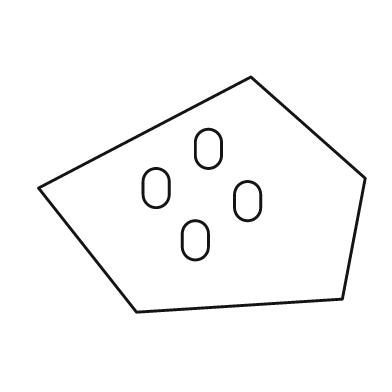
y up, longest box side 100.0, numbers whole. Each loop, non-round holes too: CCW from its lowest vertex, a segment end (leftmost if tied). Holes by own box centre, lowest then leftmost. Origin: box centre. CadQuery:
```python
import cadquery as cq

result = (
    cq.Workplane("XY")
    .moveTo(-20.0, -36.0)
    .lineTo(43.0, -32.0)
    .lineTo(50.0, 5.0)
    .lineTo(15.0, 36.0)
    .lineTo(-50.0, 2.0)
    .close()
    .moveTo(-6.0, -16.0)
    .threePointArc((-2.0, -20.0), (2.0, -16.0))
    .lineTo(2.0, -12.0)
    .threePointArc((-2.0, -8.0), (-6.0, -12.0))
    .close()
    .moveTo(10.0, -4.0)
    .threePointArc((14.0, -8.0), (18.0, -4.0))
    .lineTo(18.0, 0.0)
    .threePointArc((14.0, 4.0), (10.0, 0.0))
    .close()
    .moveTo(-18.0, 0.0)
    .threePointArc((-14.0, -4.0), (-10.0, 0.0))
    .lineTo(-10.0, 4.0)
    .threePointArc((-14.0, 8.0), (-18.0, 4.0))
    .close()
    .moveTo(-2.0, 12.0)
    .threePointArc((2.0, 8.0), (6.0, 12.0))
    .lineTo(6.0, 16.0)
    .threePointArc((2.0, 20.0), (-2.0, 16.0))
    .close()
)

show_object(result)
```